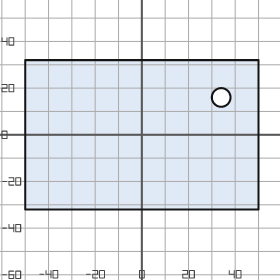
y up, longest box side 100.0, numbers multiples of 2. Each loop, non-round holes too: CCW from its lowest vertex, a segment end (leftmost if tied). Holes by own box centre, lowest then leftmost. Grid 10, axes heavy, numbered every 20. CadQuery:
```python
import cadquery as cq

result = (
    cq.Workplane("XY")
    .moveTo(-50.0, -32.0)
    .lineTo(50.0, -32.0)
    .lineTo(50.0, 32.0)
    .lineTo(-50.0, 32.0)
    .close()
    .moveTo(34.0, 16.0)
    .circle(4.0)
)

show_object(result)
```